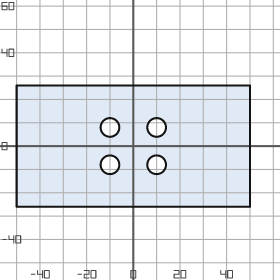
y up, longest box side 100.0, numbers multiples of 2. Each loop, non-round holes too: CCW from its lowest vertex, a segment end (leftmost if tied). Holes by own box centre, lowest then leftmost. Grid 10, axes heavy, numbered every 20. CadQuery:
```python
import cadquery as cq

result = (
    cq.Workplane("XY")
    .moveTo(-50.0, -26.0)
    .lineTo(50.0, -26.0)
    .lineTo(50.0, 26.0)
    .lineTo(-50.0, 26.0)
    .close()
    .moveTo(-10.0, -8.0)
    .circle(4.0)
    .moveTo(10.0, -8.0)
    .circle(4.0)
    .moveTo(-10.0, 8.0)
    .circle(4.0)
    .moveTo(10.0, 8.0)
    .circle(4.0)
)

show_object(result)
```